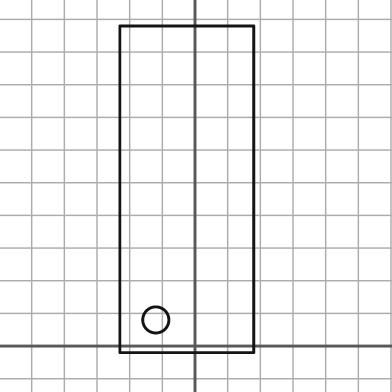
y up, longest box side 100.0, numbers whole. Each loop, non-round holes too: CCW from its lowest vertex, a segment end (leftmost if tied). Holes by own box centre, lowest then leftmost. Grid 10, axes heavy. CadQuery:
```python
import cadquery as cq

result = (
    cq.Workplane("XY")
    .moveTo(-23.0, -2.0)
    .lineTo(18.0, -2.0)
    .lineTo(18.0, 98.0)
    .lineTo(-23.0, 98.0)
    .close()
    .moveTo(-12.0, 8.0)
    .circle(4.0)
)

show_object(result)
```